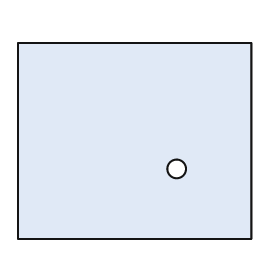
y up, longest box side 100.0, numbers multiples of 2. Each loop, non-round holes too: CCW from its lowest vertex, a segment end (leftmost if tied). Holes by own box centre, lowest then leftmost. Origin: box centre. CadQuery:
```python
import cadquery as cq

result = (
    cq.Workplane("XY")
    .moveTo(-50.0, -42.0)
    .lineTo(50.0, -42.0)
    .lineTo(50.0, 42.0)
    .lineTo(-50.0, 42.0)
    .close()
    .moveTo(18.0, -12.0)
    .circle(4.0)
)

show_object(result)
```